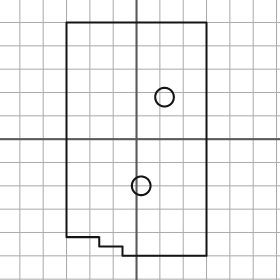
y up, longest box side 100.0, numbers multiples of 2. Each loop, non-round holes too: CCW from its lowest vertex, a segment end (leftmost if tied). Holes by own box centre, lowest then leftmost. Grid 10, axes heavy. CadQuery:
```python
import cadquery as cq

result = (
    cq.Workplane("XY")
    .moveTo(-6.0, -50.0)
    .lineTo(30.0, -50.0)
    .lineTo(30.0, 50.0)
    .lineTo(-30.0, 50.0)
    .lineTo(-30.0, -42.0)
    .lineTo(-16.0, -42.0)
    .lineTo(-16.0, -46.0)
    .lineTo(-6.0, -46.0)
    .close()
    .moveTo(2.0, -20.0)
    .circle(4.0)
    .moveTo(12.0, 18.0)
    .circle(4.0)
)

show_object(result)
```